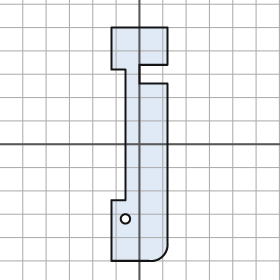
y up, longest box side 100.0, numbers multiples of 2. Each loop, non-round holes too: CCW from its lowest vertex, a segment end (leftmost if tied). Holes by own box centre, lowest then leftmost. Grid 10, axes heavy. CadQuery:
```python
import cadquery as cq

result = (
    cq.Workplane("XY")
    .moveTo(-12.0, -50.0)
    .lineTo(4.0, -50.0)
    .threePointArc((10.0, -48.0), (12.0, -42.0))
    .lineTo(12.0, 26.0)
    .lineTo(0.0, 26.0)
    .lineTo(0.0, 34.0)
    .lineTo(12.0, 34.0)
    .lineTo(12.0, 50.0)
    .lineTo(-12.0, 50.0)
    .lineTo(-12.0, 32.0)
    .lineTo(-6.0, 32.0)
    .lineTo(-6.0, -24.0)
    .lineTo(-12.0, -24.0)
    .close()
    .moveTo(-6.0, -32.0)
    .circle(2.0)
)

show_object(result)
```